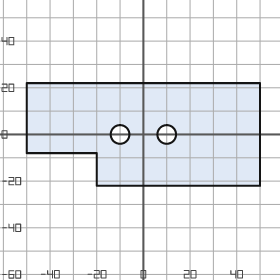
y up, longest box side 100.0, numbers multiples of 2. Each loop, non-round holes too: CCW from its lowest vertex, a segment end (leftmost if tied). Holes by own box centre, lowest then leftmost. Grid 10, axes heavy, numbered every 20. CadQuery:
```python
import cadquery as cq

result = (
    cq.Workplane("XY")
    .moveTo(-20.0, -22.0)
    .lineTo(50.0, -22.0)
    .lineTo(50.0, 22.0)
    .lineTo(-50.0, 22.0)
    .lineTo(-50.0, -8.0)
    .lineTo(-20.0, -8.0)
    .close()
    .moveTo(-10.0, 0.0)
    .circle(4.0)
    .moveTo(10.0, 0.0)
    .circle(4.0)
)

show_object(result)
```